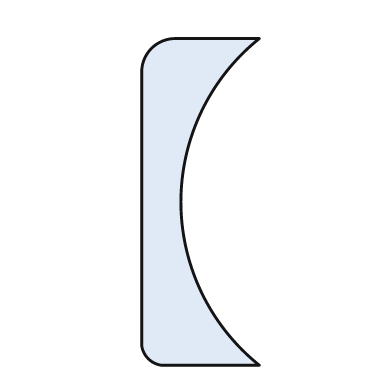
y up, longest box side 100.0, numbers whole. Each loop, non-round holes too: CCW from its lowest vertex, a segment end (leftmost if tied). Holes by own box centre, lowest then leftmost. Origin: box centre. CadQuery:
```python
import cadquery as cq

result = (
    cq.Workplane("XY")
    .moveTo(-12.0, -50.0)
    .lineTo(18.0, -50.0)
    .threePointArc((-6.0, 0.0), (18.0, 50.0))
    .lineTo(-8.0, 50.0)
    .threePointArc((-15.0, 47.0), (-18.0, 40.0))
    .lineTo(-18.0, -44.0)
    .threePointArc((-16.0, -48.0), (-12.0, -50.0))
    .close()
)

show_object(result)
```